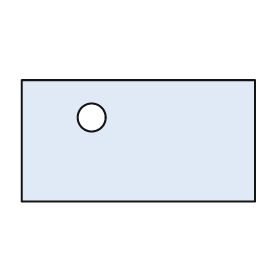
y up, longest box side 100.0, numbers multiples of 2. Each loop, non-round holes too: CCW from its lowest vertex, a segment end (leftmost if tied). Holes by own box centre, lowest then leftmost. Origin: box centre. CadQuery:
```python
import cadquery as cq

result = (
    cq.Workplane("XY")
    .moveTo(-50.0, -26.0)
    .lineTo(50.0, -26.0)
    .lineTo(50.0, 26.0)
    .lineTo(-50.0, 26.0)
    .close()
    .moveTo(-20.0, 10.0)
    .circle(6.0)
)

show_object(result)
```